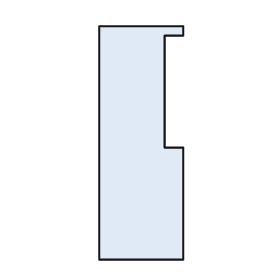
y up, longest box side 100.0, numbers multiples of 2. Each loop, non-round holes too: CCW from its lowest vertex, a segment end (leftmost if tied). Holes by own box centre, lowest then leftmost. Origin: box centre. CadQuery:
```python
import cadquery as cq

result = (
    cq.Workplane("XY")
    .moveTo(-18.0, -50.0)
    .lineTo(18.0, -50.0)
    .lineTo(18.0, -2.0)
    .lineTo(10.0, -2.0)
    .lineTo(10.0, 46.0)
    .lineTo(18.0, 46.0)
    .lineTo(18.0, 50.0)
    .lineTo(-18.0, 50.0)
    .close()
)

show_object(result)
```